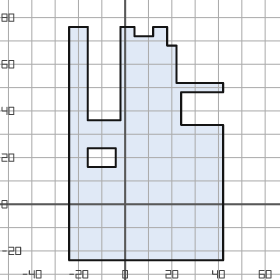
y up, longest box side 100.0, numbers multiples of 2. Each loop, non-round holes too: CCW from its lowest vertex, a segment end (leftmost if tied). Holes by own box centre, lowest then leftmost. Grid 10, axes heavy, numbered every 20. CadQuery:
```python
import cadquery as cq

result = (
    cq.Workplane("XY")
    .moveTo(-24.0, -24.0)
    .lineTo(42.0, -24.0)
    .lineTo(42.0, 34.0)
    .lineTo(24.0, 34.0)
    .lineTo(24.0, 48.0)
    .lineTo(42.0, 48.0)
    .lineTo(42.0, 52.0)
    .lineTo(22.0, 52.0)
    .lineTo(22.0, 68.0)
    .lineTo(18.0, 68.0)
    .lineTo(18.0, 76.0)
    .lineTo(12.0, 76.0)
    .lineTo(12.0, 72.0)
    .lineTo(4.0, 72.0)
    .lineTo(4.0, 76.0)
    .lineTo(-2.0, 76.0)
    .lineTo(-2.0, 36.0)
    .lineTo(-16.0, 36.0)
    .lineTo(-16.0, 76.0)
    .lineTo(-24.0, 76.0)
    .close()
    .moveTo(-16.0, 16.0)
    .lineTo(-4.0, 16.0)
    .lineTo(-4.0, 24.0)
    .lineTo(-16.0, 24.0)
    .close()
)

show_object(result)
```